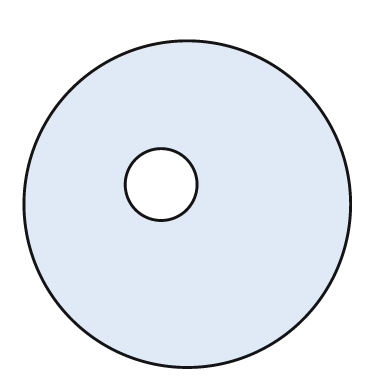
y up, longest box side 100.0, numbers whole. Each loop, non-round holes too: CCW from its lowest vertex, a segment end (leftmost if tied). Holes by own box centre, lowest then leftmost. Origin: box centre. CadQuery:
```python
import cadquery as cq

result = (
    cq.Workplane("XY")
    .moveTo(0.0, 0.0)
    .circle(50.0)
    .moveTo(-8.0, 6.0)
    .circle(11.0)
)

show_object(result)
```